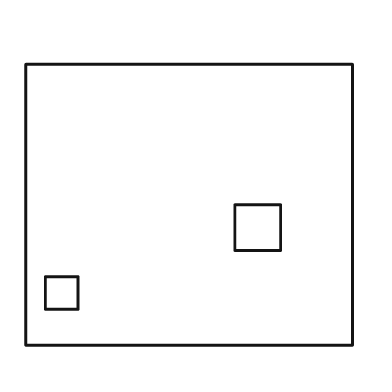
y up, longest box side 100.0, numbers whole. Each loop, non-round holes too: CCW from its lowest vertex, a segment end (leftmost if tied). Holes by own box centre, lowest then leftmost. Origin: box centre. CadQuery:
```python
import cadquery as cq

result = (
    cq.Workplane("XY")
    .moveTo(-50.0, -43.0)
    .lineTo(50.0, -43.0)
    .lineTo(50.0, 43.0)
    .lineTo(-50.0, 43.0)
    .close()
    .moveTo(-44.0, -32.0)
    .lineTo(-34.0, -32.0)
    .lineTo(-34.0, -22.0)
    .lineTo(-44.0, -22.0)
    .close()
    .moveTo(14.0, -14.0)
    .lineTo(28.0, -14.0)
    .lineTo(28.0, 0.0)
    .lineTo(14.0, 0.0)
    .close()
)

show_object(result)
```